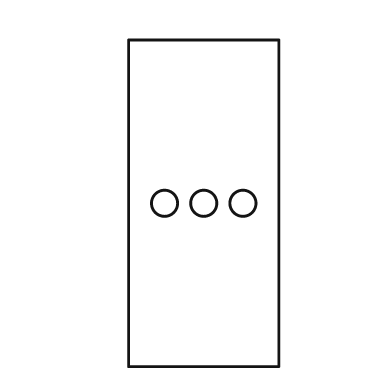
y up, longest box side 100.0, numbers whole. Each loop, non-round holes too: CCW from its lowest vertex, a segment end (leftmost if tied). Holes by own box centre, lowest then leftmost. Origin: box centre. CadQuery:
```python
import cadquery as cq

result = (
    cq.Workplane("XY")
    .moveTo(-23.0, -50.0)
    .lineTo(23.0, -50.0)
    .lineTo(23.0, 50.0)
    .lineTo(-23.0, 50.0)
    .close()
    .moveTo(-12.0, 0.0)
    .circle(4.0)
    .moveTo(0.0, 0.0)
    .circle(4.0)
    .moveTo(12.0, 0.0)
    .circle(4.0)
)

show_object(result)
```